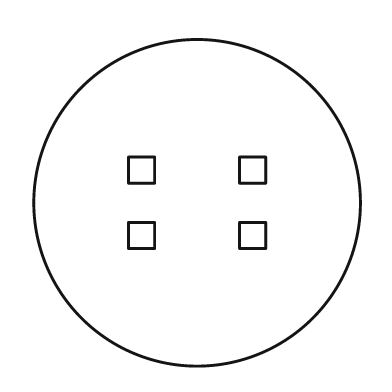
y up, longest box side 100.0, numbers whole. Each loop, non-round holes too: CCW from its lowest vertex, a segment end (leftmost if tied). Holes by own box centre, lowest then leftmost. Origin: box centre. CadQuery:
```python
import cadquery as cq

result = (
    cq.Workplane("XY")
    .moveTo(0.0, 0.0)
    .circle(50.0)
    .moveTo(-21.0, -14.0)
    .lineTo(-13.0, -14.0)
    .lineTo(-13.0, -6.0)
    .lineTo(-21.0, -6.0)
    .close()
    .moveTo(13.0, -14.0)
    .lineTo(21.0, -14.0)
    .lineTo(21.0, -6.0)
    .lineTo(13.0, -6.0)
    .close()
    .moveTo(-21.0, 6.0)
    .lineTo(-13.0, 6.0)
    .lineTo(-13.0, 14.0)
    .lineTo(-21.0, 14.0)
    .close()
    .moveTo(13.0, 6.0)
    .lineTo(21.0, 6.0)
    .lineTo(21.0, 14.0)
    .lineTo(13.0, 14.0)
    .close()
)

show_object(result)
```